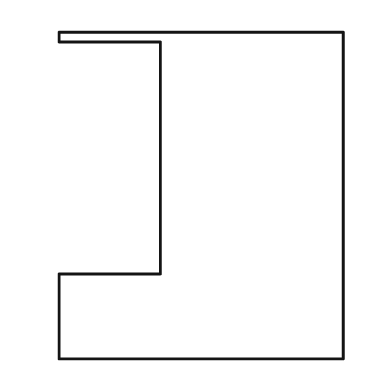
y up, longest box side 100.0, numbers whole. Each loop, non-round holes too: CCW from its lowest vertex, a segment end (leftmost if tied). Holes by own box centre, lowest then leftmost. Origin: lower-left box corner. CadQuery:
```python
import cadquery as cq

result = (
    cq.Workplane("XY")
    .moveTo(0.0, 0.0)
    .lineTo(87.0, 0.0)
    .lineTo(87.0, 100.0)
    .lineTo(0.0, 100.0)
    .lineTo(0.0, 97.0)
    .lineTo(31.0, 97.0)
    .lineTo(31.0, 26.0)
    .lineTo(0.0, 26.0)
    .close()
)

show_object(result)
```